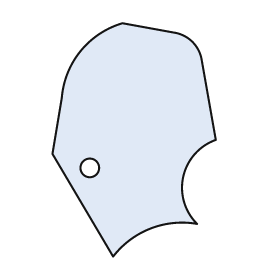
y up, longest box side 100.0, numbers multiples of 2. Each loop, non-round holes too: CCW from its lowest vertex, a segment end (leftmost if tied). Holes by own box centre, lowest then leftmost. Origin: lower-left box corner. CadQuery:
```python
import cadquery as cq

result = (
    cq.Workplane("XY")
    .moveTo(26.0, 0.0)
    .threePointArc((42.0, 12.0), (62.0, 14.0))
    .threePointArc((56.0, 34.0), (70.0, 50.0))
    .lineTo(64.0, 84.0)
    .threePointArc((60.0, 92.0), (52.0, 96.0))
    .lineTo(30.0, 100.0)
    .threePointArc((12.0, 88.0), (4.0, 68.0))
    .lineTo(0.0, 44.0)
    .close()
    .moveTo(16.0, 38.0)
    .circle(4.0)
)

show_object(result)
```